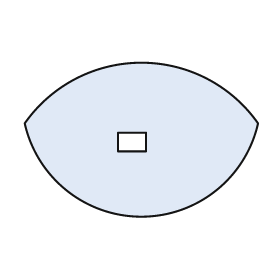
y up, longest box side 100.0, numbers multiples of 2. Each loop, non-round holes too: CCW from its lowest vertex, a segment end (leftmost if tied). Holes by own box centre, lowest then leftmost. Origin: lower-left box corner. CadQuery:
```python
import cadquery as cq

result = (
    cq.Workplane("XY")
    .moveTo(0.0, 40.0)
    .threePointArc((50.0, 0.0), (100.0, 40.0))
    .threePointArc((50.0, 66.0), (0.0, 40.0))
    .close()
    .moveTo(40.0, 28.0)
    .lineTo(52.0, 28.0)
    .lineTo(52.0, 36.0)
    .lineTo(40.0, 36.0)
    .close()
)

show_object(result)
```